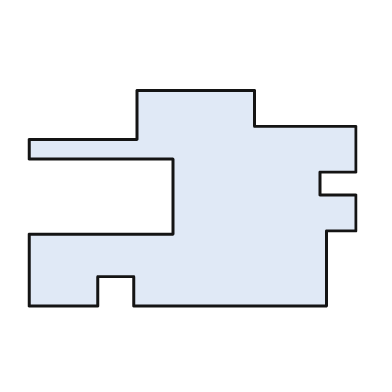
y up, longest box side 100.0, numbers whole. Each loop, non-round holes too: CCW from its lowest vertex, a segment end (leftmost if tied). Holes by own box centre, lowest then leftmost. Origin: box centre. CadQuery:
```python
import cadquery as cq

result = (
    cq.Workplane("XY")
    .moveTo(-50.0, -33.0)
    .lineTo(-29.0, -33.0)
    .lineTo(-29.0, -24.0)
    .lineTo(-18.0, -24.0)
    .lineTo(-18.0, -33.0)
    .lineTo(41.0, -33.0)
    .lineTo(41.0, -10.0)
    .lineTo(50.0, -10.0)
    .lineTo(50.0, 1.0)
    .lineTo(39.0, 1.0)
    .lineTo(39.0, 8.0)
    .lineTo(50.0, 8.0)
    .lineTo(50.0, 22.0)
    .lineTo(19.0, 22.0)
    .lineTo(19.0, 33.0)
    .lineTo(-17.0, 33.0)
    .lineTo(-17.0, 18.0)
    .lineTo(-50.0, 18.0)
    .lineTo(-50.0, 12.0)
    .lineTo(-6.0, 12.0)
    .lineTo(-6.0, -11.0)
    .lineTo(-50.0, -11.0)
    .close()
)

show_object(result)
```